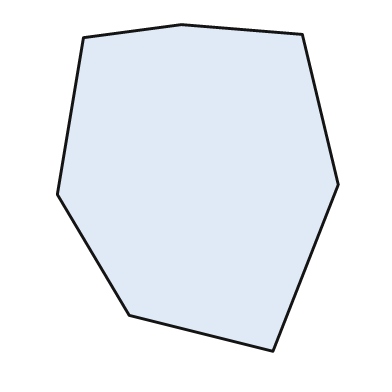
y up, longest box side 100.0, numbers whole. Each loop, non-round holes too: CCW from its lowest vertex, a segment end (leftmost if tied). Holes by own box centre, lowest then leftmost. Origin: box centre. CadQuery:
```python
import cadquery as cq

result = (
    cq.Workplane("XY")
    .moveTo(23.0, -50.0)
    .lineTo(43.0, 1.0)
    .lineTo(32.0, 47.0)
    .lineTo(-5.0, 50.0)
    .lineTo(-35.0, 46.0)
    .lineTo(-43.0, -2.0)
    .lineTo(-21.0, -39.0)
    .close()
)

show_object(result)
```